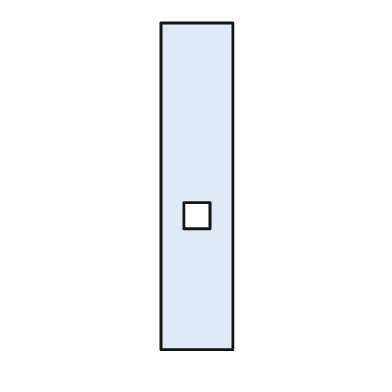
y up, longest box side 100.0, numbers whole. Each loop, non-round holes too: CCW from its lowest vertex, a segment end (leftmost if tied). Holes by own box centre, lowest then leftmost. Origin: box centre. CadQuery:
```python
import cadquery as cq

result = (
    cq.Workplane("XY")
    .moveTo(-11.0, -50.0)
    .lineTo(11.0, -50.0)
    .lineTo(11.0, 50.0)
    .lineTo(-11.0, 50.0)
    .close()
    .moveTo(-4.0, -13.0)
    .lineTo(4.0, -13.0)
    .lineTo(4.0, -5.0)
    .lineTo(-4.0, -5.0)
    .close()
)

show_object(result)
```